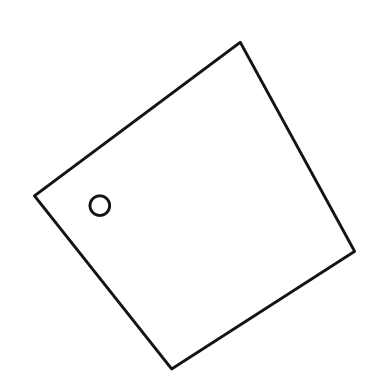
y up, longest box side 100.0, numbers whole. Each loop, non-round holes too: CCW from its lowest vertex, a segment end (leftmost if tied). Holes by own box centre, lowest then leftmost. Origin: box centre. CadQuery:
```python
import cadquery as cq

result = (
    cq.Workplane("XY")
    .moveTo(-7.0, -50.0)
    .lineTo(49.0, -14.0)
    .lineTo(14.0, 50.0)
    .lineTo(-49.0, 3.0)
    .close()
    .moveTo(-29.0, 0.0)
    .circle(3.0)
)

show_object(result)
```